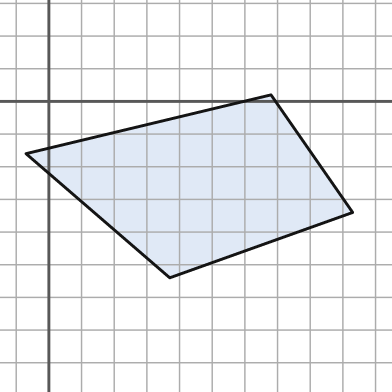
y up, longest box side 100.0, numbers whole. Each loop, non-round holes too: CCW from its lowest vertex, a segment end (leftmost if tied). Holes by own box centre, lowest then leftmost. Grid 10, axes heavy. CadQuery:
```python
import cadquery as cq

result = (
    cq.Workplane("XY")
    .moveTo(37.0, -54.0)
    .lineTo(93.0, -34.0)
    .lineTo(68.0, 2.0)
    .lineTo(-7.0, -16.0)
    .close()
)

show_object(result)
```